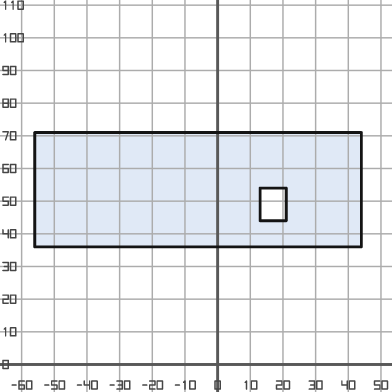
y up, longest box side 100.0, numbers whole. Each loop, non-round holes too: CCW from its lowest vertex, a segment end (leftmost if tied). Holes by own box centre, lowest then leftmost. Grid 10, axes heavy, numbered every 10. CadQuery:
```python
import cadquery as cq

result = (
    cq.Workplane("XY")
    .moveTo(-56.0, 36.0)
    .lineTo(44.0, 36.0)
    .lineTo(44.0, 71.0)
    .lineTo(-56.0, 71.0)
    .close()
    .moveTo(13.0, 44.0)
    .lineTo(21.0, 44.0)
    .lineTo(21.0, 54.0)
    .lineTo(13.0, 54.0)
    .close()
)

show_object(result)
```